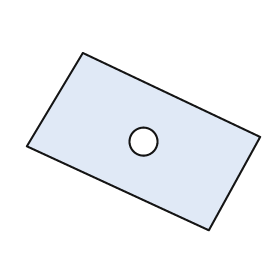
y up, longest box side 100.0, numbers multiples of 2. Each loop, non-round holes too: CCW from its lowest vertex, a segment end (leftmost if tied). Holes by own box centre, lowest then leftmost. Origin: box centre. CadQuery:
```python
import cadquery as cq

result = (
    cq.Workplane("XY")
    .moveTo(28.0, -38.0)
    .lineTo(50.0, 2.0)
    .lineTo(-26.0, 38.0)
    .lineTo(-50.0, -2.0)
    .close()
    .moveTo(0.0, 0.0)
    .circle(6.0)
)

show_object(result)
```